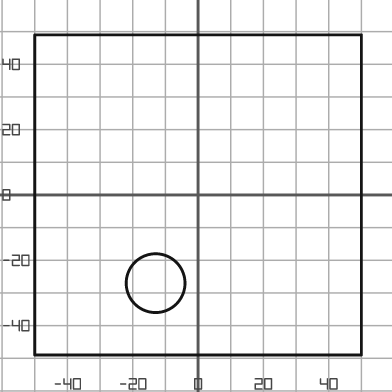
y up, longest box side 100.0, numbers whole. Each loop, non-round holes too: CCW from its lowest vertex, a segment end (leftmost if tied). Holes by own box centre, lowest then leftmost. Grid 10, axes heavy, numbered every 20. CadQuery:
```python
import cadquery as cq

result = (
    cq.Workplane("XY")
    .moveTo(-50.0, -49.0)
    .lineTo(50.0, -49.0)
    .lineTo(50.0, 49.0)
    .lineTo(-50.0, 49.0)
    .close()
    .moveTo(-13.0, -27.0)
    .circle(9.0)
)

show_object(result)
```